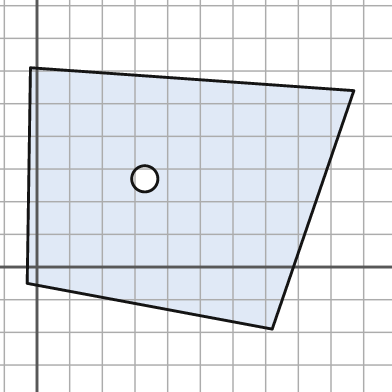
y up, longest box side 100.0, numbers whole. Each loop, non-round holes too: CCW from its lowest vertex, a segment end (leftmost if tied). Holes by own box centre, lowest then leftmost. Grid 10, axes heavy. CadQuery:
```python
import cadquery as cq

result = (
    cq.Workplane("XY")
    .moveTo(72.0, -19.0)
    .lineTo(97.0, 54.0)
    .lineTo(-2.0, 61.0)
    .lineTo(-3.0, -5.0)
    .close()
    .moveTo(33.0, 27.0)
    .circle(4.0)
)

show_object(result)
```